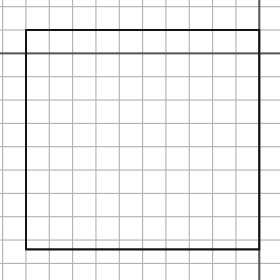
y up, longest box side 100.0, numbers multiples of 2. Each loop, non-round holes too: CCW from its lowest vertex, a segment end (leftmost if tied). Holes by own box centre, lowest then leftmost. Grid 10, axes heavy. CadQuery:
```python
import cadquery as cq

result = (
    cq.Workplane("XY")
    .moveTo(-100.0, -84.0)
    .lineTo(0.0, -84.0)
    .lineTo(0.0, 10.0)
    .lineTo(-100.0, 10.0)
    .close()
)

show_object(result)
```